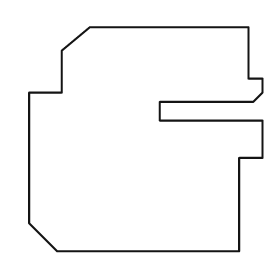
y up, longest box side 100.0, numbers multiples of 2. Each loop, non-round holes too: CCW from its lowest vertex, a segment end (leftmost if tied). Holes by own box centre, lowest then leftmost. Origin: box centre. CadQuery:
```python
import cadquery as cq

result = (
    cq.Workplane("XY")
    .moveTo(-38.0, -48.0)
    .lineTo(40.0, -48.0)
    .lineTo(40.0, -8.0)
    .lineTo(50.0, -8.0)
    .lineTo(50.0, 8.0)
    .lineTo(6.0, 8.0)
    .lineTo(6.0, 16.0)
    .lineTo(46.0, 16.0)
    .lineTo(50.0, 20.0)
    .lineTo(50.0, 26.0)
    .lineTo(44.0, 26.0)
    .lineTo(44.0, 48.0)
    .lineTo(-24.0, 48.0)
    .lineTo(-36.0, 38.0)
    .lineTo(-36.0, 20.0)
    .lineTo(-50.0, 20.0)
    .lineTo(-50.0, -36.0)
    .close()
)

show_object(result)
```